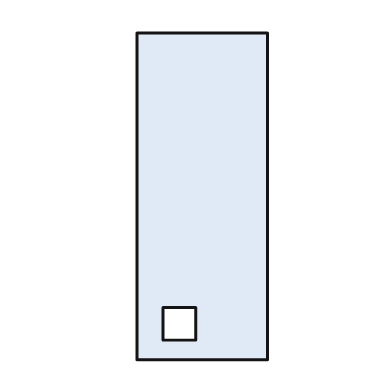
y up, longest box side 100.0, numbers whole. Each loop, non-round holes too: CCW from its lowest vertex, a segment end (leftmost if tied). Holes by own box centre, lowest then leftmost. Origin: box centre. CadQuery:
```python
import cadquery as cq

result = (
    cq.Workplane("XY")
    .moveTo(-20.0, -50.0)
    .lineTo(20.0, -50.0)
    .lineTo(20.0, 50.0)
    .lineTo(-20.0, 50.0)
    .close()
    .moveTo(-12.0, -44.0)
    .lineTo(-2.0, -44.0)
    .lineTo(-2.0, -34.0)
    .lineTo(-12.0, -34.0)
    .close()
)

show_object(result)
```